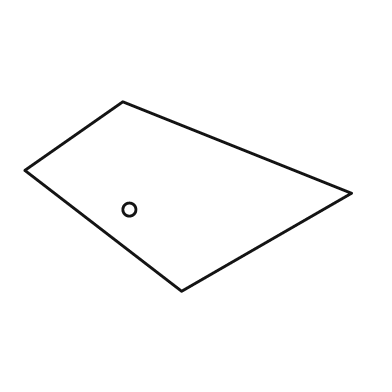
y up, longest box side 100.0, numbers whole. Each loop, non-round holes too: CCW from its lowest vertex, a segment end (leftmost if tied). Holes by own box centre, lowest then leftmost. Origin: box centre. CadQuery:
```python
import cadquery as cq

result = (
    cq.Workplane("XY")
    .moveTo(-2.0, -29.0)
    .lineTo(50.0, 1.0)
    .lineTo(-20.0, 29.0)
    .lineTo(-50.0, 8.0)
    .close()
    .moveTo(-18.0, -4.0)
    .circle(2.0)
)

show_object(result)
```